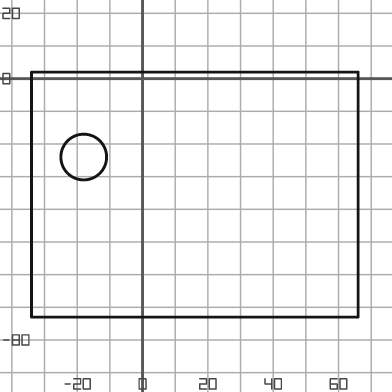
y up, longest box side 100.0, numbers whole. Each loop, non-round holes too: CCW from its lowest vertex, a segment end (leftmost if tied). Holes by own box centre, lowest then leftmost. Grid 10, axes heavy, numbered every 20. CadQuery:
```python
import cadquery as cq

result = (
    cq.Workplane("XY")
    .moveTo(-34.0, -73.0)
    .lineTo(66.0, -73.0)
    .lineTo(66.0, 2.0)
    .lineTo(-34.0, 2.0)
    .close()
    .moveTo(-18.0, -24.0)
    .circle(7.0)
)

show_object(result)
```